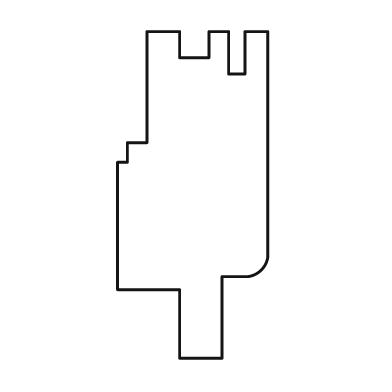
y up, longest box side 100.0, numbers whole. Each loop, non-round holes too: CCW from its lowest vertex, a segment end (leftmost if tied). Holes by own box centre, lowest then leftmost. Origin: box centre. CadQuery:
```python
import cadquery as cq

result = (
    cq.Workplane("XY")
    .moveTo(-4.0, -50.0)
    .lineTo(9.0, -50.0)
    .lineTo(9.0, -25.0)
    .lineTo(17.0, -25.0)
    .threePointArc((21.0, -23.0), (23.0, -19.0))
    .lineTo(23.0, 50.0)
    .lineTo(16.0, 50.0)
    .lineTo(16.0, 37.0)
    .lineTo(11.0, 37.0)
    .lineTo(11.0, 50.0)
    .lineTo(5.0, 50.0)
    .lineTo(5.0, 42.0)
    .lineTo(-4.0, 42.0)
    .lineTo(-4.0, 50.0)
    .lineTo(-14.0, 50.0)
    .lineTo(-14.0, 16.0)
    .lineTo(-20.0, 16.0)
    .lineTo(-20.0, 10.0)
    .lineTo(-23.0, 10.0)
    .lineTo(-23.0, -29.0)
    .lineTo(-4.0, -29.0)
    .close()
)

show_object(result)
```